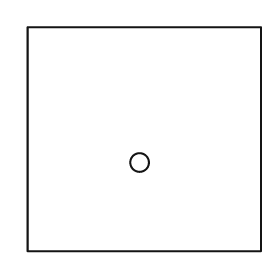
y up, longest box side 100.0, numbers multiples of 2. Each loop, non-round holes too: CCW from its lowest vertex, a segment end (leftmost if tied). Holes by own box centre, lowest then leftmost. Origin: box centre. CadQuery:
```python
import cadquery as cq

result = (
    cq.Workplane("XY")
    .moveTo(-50.0, -48.0)
    .lineTo(50.0, -48.0)
    .lineTo(50.0, 48.0)
    .lineTo(-50.0, 48.0)
    .close()
    .moveTo(-2.0, -10.0)
    .circle(4.0)
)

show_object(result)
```